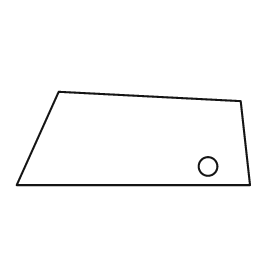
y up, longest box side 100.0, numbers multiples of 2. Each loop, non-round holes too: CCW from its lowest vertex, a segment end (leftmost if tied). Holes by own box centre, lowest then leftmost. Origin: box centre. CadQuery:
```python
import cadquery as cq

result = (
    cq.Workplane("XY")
    .moveTo(-50.0, -20.0)
    .lineTo(50.0, -20.0)
    .lineTo(46.0, 16.0)
    .lineTo(-32.0, 20.0)
    .close()
    .moveTo(32.0, -12.0)
    .circle(4.0)
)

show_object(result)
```